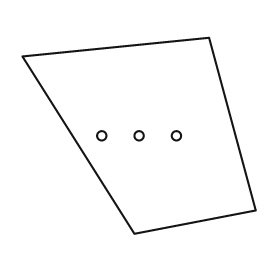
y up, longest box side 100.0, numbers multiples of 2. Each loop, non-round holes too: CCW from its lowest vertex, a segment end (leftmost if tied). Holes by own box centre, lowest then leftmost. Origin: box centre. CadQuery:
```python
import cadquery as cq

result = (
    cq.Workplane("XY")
    .moveTo(-2.0, -42.0)
    .lineTo(50.0, -32.0)
    .lineTo(30.0, 42.0)
    .lineTo(-50.0, 34.0)
    .close()
    .moveTo(-16.0, 0.0)
    .circle(2.0)
    .moveTo(0.0, 0.0)
    .circle(2.0)
    .moveTo(16.0, 0.0)
    .circle(2.0)
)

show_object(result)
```